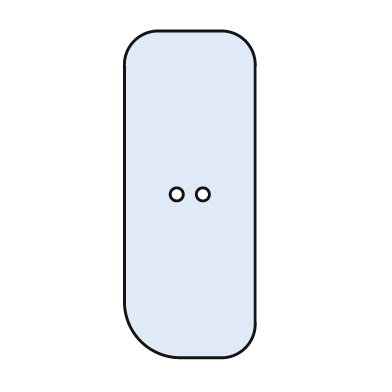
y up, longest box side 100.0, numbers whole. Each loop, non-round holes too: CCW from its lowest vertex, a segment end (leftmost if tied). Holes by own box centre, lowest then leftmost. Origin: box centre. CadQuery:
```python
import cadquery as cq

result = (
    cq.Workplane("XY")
    .moveTo(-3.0, -50.0)
    .lineTo(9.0, -50.0)
    .threePointArc((17.0, -47.0), (20.0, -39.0))
    .lineTo(20.0, 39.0)
    .threePointArc((17.0, 47.0), (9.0, 50.0))
    .lineTo(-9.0, 50.0)
    .threePointArc((-17.0, 47.0), (-20.0, 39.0))
    .lineTo(-20.0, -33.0)
    .threePointArc((-15.0, -45.0), (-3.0, -50.0))
    .close()
    .moveTo(-4.0, 0.0)
    .circle(2.0)
    .moveTo(4.0, 0.0)
    .circle(2.0)
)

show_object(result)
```